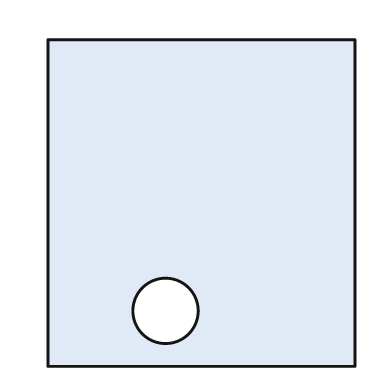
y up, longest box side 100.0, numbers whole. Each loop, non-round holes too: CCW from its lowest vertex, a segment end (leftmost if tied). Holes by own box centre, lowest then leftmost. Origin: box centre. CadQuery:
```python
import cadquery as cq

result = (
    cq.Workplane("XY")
    .moveTo(-47.0, -50.0)
    .lineTo(47.0, -50.0)
    .lineTo(47.0, 50.0)
    .lineTo(-47.0, 50.0)
    .close()
    .moveTo(-11.0, -33.0)
    .circle(10.0)
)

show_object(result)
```